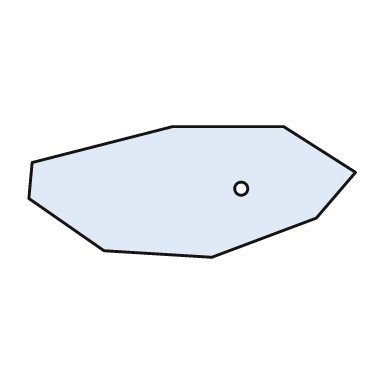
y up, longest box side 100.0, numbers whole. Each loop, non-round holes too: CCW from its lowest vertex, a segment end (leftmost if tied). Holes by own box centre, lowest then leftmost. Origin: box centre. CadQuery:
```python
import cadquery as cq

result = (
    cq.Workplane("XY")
    .moveTo(6.0, -20.0)
    .lineTo(38.0, -8.0)
    .lineTo(50.0, 6.0)
    .lineTo(28.0, 20.0)
    .lineTo(-6.0, 20.0)
    .lineTo(-49.0, 9.0)
    .lineTo(-50.0, -2.0)
    .lineTo(-27.0, -18.0)
    .close()
    .moveTo(15.0, 1.0)
    .circle(2.0)
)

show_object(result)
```